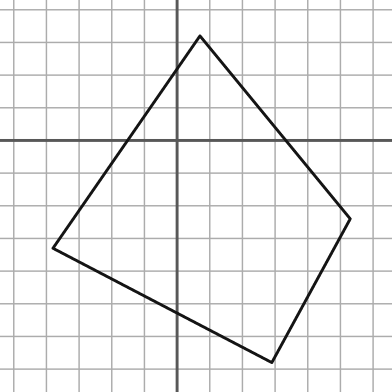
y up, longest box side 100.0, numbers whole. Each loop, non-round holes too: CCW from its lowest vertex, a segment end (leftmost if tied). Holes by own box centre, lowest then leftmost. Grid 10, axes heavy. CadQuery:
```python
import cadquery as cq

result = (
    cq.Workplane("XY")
    .moveTo(29.0, -68.0)
    .lineTo(53.0, -24.0)
    .lineTo(7.0, 32.0)
    .lineTo(-38.0, -33.0)
    .close()
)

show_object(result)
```